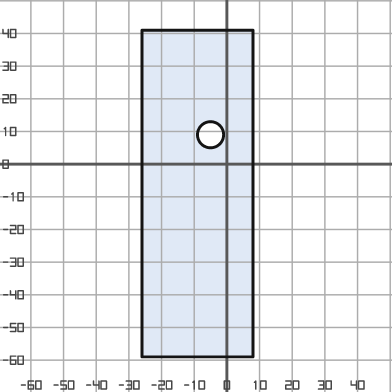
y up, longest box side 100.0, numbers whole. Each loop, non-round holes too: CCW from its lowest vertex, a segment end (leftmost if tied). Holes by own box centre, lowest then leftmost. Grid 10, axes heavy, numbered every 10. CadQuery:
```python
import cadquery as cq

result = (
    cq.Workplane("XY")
    .moveTo(-26.0, -59.0)
    .lineTo(8.0, -59.0)
    .lineTo(8.0, 41.0)
    .lineTo(-26.0, 41.0)
    .close()
    .moveTo(-5.0, 9.0)
    .circle(4.0)
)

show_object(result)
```